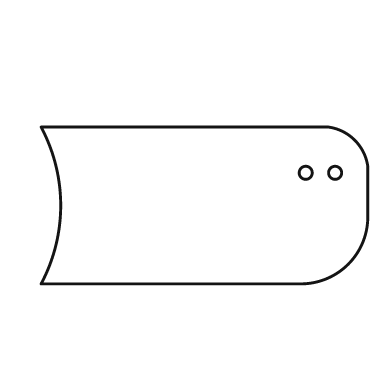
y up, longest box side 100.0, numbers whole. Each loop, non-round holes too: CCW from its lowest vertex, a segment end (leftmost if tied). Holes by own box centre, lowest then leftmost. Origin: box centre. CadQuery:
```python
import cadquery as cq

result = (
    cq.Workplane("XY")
    .moveTo(-50.0, -24.0)
    .lineTo(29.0, -24.0)
    .threePointArc((44.0, -18.0), (50.0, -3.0))
    .lineTo(50.0, 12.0)
    .threePointArc((46.0, 20.0), (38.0, 24.0))
    .lineTo(-50.0, 24.0)
    .threePointArc((-44.0, 0.0), (-50.0, -24.0))
    .close()
    .moveTo(31.0, 10.0)
    .circle(2.0)
    .moveTo(40.0, 10.0)
    .circle(2.0)
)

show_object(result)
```